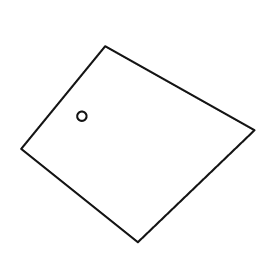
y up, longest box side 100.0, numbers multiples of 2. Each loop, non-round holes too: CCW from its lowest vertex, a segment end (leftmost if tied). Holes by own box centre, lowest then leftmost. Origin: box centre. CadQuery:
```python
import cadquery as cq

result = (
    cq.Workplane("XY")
    .moveTo(0.0, -42.0)
    .lineTo(50.0, 6.0)
    .lineTo(-14.0, 42.0)
    .lineTo(-50.0, -2.0)
    .close()
    .moveTo(-24.0, 12.0)
    .circle(2.0)
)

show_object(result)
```